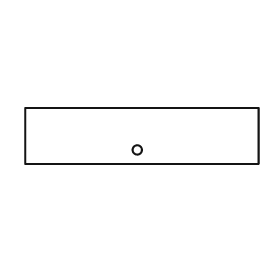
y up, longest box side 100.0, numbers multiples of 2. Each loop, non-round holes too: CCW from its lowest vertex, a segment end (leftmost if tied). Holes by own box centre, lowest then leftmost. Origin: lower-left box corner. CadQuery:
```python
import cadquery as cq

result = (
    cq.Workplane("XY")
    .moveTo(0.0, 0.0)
    .lineTo(100.0, 0.0)
    .lineTo(100.0, 24.0)
    .lineTo(0.0, 24.0)
    .close()
    .moveTo(48.0, 6.0)
    .circle(2.0)
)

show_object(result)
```